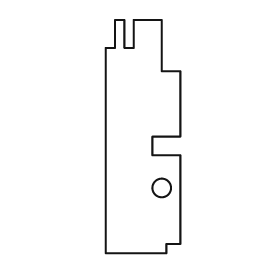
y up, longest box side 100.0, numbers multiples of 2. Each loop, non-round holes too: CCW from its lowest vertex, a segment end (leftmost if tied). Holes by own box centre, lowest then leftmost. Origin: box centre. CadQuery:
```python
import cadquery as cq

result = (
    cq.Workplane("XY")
    .moveTo(-16.0, -50.0)
    .lineTo(10.0, -50.0)
    .lineTo(10.0, -46.0)
    .lineTo(16.0, -46.0)
    .lineTo(16.0, -8.0)
    .lineTo(4.0, -8.0)
    .lineTo(4.0, 0.0)
    .lineTo(16.0, 0.0)
    .lineTo(16.0, 28.0)
    .lineTo(8.0, 28.0)
    .lineTo(8.0, 50.0)
    .lineTo(-4.0, 50.0)
    .lineTo(-4.0, 38.0)
    .lineTo(-8.0, 38.0)
    .lineTo(-8.0, 50.0)
    .lineTo(-12.0, 50.0)
    .lineTo(-12.0, 38.0)
    .lineTo(-16.0, 38.0)
    .close()
    .moveTo(8.0, -22.0)
    .circle(4.0)
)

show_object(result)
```